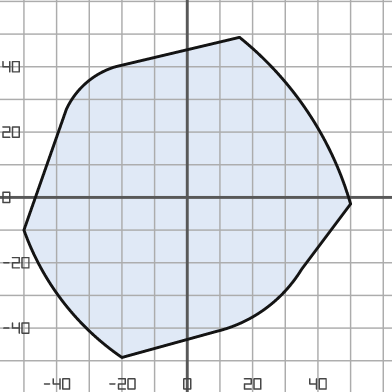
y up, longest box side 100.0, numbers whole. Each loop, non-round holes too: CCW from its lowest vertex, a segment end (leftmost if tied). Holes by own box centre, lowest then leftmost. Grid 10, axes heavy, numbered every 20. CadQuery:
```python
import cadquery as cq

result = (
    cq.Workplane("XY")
    .moveTo(-20.0, -49.0)
    .lineTo(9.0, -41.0)
    .threePointArc((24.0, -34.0), (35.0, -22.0))
    .lineTo(50.0, -2.0)
    .threePointArc((37.0, 26.0), (16.0, 49.0))
    .lineTo(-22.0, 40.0)
    .threePointArc((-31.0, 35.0), (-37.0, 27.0))
    .lineTo(-50.0, -10.0)
    .threePointArc((-38.0, -32.0), (-20.0, -49.0))
    .close()
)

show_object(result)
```